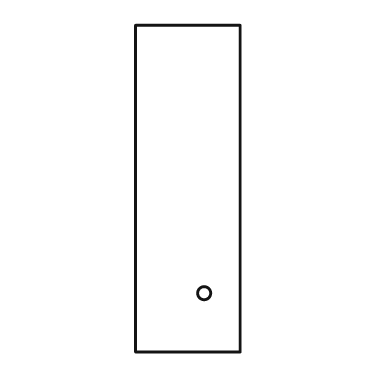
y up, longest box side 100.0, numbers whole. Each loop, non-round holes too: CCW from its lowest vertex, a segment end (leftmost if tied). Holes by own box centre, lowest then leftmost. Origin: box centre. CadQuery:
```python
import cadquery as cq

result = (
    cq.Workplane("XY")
    .moveTo(-16.0, -50.0)
    .lineTo(16.0, -50.0)
    .lineTo(16.0, 50.0)
    .lineTo(-16.0, 50.0)
    .close()
    .moveTo(5.0, -32.0)
    .circle(2.0)
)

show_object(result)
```